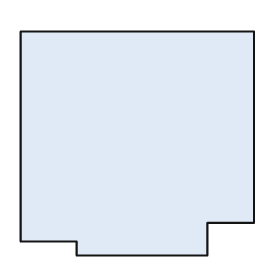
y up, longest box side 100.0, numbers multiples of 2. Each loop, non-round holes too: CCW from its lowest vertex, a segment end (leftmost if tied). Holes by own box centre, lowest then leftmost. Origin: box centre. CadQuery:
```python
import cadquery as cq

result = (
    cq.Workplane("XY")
    .moveTo(-26.0, -48.0)
    .lineTo(30.0, -48.0)
    .lineTo(30.0, -34.0)
    .lineTo(50.0, -34.0)
    .lineTo(50.0, 48.0)
    .lineTo(-50.0, 48.0)
    .lineTo(-50.0, -42.0)
    .lineTo(-26.0, -42.0)
    .close()
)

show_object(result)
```